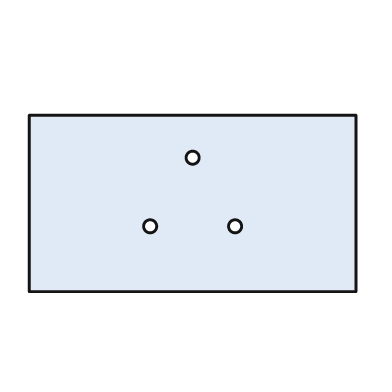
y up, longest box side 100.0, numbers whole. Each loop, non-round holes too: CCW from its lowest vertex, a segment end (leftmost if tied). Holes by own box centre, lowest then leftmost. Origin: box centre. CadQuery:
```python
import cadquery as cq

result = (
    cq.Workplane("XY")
    .moveTo(-50.0, -27.0)
    .lineTo(50.0, -27.0)
    .lineTo(50.0, 27.0)
    .lineTo(-50.0, 27.0)
    .close()
    .moveTo(-13.0, -7.0)
    .circle(2.0)
    .moveTo(13.0, -7.0)
    .circle(2.0)
    .moveTo(0.0, 14.0)
    .circle(2.0)
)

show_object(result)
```